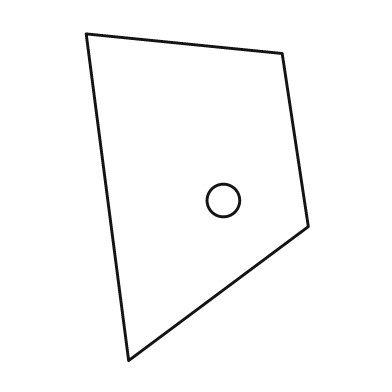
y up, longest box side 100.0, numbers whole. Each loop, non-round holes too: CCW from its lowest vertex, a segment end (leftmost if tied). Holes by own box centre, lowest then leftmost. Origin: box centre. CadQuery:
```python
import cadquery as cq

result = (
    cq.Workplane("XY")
    .moveTo(-21.0, -50.0)
    .lineTo(34.0, -9.0)
    .lineTo(26.0, 44.0)
    .lineTo(-34.0, 50.0)
    .close()
    .moveTo(8.0, -1.0)
    .circle(5.0)
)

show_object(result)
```